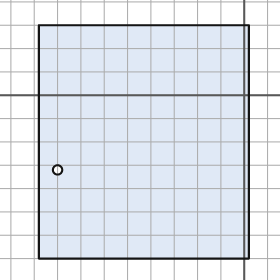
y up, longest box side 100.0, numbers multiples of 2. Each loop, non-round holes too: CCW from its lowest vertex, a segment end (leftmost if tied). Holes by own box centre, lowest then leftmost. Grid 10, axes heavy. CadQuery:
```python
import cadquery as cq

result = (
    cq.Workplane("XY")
    .moveTo(-88.0, -70.0)
    .lineTo(2.0, -70.0)
    .lineTo(2.0, 30.0)
    .lineTo(-88.0, 30.0)
    .close()
    .moveTo(-80.0, -32.0)
    .circle(2.0)
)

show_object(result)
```